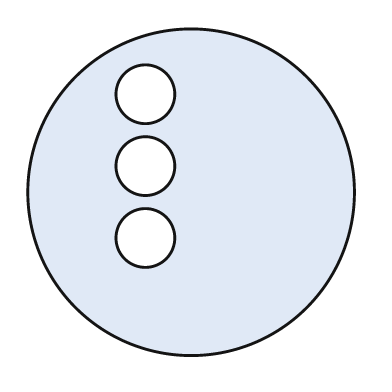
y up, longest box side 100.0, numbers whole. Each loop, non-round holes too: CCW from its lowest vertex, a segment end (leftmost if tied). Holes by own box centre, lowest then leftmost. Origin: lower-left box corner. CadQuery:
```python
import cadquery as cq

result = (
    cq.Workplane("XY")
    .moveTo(50.0, 50.0)
    .circle(50.0)
    .moveTo(36.0, 36.0)
    .circle(9.0)
    .moveTo(36.0, 58.0)
    .circle(9.0)
    .moveTo(36.0, 80.0)
    .circle(9.0)
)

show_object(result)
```